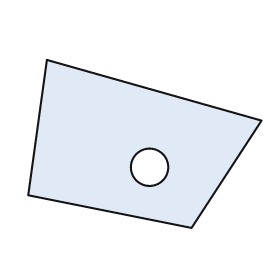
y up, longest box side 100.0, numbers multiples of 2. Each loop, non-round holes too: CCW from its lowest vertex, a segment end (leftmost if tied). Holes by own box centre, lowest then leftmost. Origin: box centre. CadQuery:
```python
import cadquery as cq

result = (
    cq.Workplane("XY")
    .moveTo(20.0, -36.0)
    .lineTo(50.0, 10.0)
    .lineTo(-42.0, 36.0)
    .lineTo(-50.0, -22.0)
    .close()
    .moveTo(2.0, -10.0)
    .circle(8.0)
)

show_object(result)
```